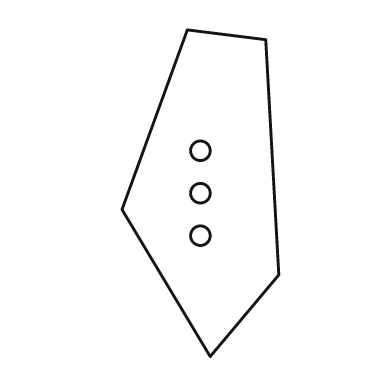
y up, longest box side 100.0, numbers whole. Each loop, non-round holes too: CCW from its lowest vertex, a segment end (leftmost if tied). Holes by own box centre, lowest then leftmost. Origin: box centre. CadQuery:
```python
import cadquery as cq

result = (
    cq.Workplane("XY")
    .moveTo(3.0, -50.0)
    .lineTo(24.0, -25.0)
    .lineTo(20.0, 47.0)
    .lineTo(-4.0, 50.0)
    .lineTo(-24.0, -5.0)
    .close()
    .moveTo(0.0, -13.0)
    .circle(3.0)
    .moveTo(0.0, 0.0)
    .circle(3.0)
    .moveTo(0.0, 13.0)
    .circle(3.0)
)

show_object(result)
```